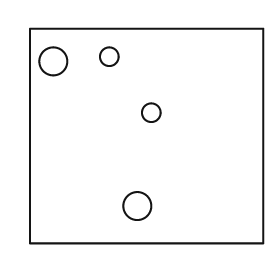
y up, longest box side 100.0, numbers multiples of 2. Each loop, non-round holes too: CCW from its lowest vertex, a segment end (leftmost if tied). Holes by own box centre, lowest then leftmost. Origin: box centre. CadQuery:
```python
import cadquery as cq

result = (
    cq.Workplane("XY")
    .moveTo(-50.0, -46.0)
    .lineTo(50.0, -46.0)
    .lineTo(50.0, 46.0)
    .lineTo(-50.0, 46.0)
    .close()
    .moveTo(-4.0, -30.0)
    .circle(6.0)
    .moveTo(2.0, 10.0)
    .circle(4.0)
    .moveTo(-40.0, 32.0)
    .circle(6.0)
    .moveTo(-16.0, 34.0)
    .circle(4.0)
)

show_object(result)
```